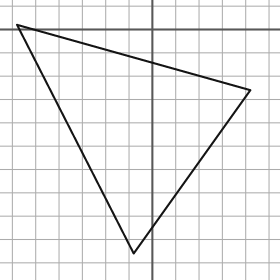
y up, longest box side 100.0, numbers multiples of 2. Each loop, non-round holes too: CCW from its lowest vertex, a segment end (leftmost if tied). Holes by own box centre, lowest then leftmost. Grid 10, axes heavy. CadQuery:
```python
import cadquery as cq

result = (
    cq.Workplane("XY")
    .moveTo(-8.0, -96.0)
    .lineTo(42.0, -26.0)
    .lineTo(-58.0, 2.0)
    .close()
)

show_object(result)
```